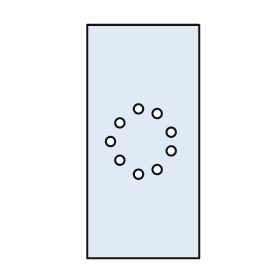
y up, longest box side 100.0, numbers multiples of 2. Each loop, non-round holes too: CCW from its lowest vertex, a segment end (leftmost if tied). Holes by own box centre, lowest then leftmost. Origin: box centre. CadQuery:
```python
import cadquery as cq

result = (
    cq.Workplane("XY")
    .moveTo(-24.0, -50.0)
    .lineTo(24.0, -50.0)
    .lineTo(24.0, 50.0)
    .lineTo(-24.0, 50.0)
    .close()
    .moveTo(-2.0, -14.0)
    .circle(2.0)
    .moveTo(6.0, -12.0)
    .circle(2.0)
    .moveTo(-10.0, -8.0)
    .circle(2.0)
    .moveTo(12.0, -4.0)
    .circle(2.0)
    .moveTo(-14.0, 0.0)
    .circle(2.0)
    .moveTo(12.0, 4.0)
    .circle(2.0)
    .moveTo(-10.0, 8.0)
    .circle(2.0)
    .moveTo(6.0, 12.0)
    .circle(2.0)
    .moveTo(-2.0, 14.0)
    .circle(2.0)
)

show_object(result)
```